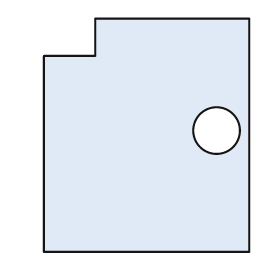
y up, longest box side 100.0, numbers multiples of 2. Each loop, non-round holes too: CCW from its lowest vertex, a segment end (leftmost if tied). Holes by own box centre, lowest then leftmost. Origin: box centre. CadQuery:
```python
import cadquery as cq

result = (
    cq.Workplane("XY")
    .moveTo(-44.0, -50.0)
    .lineTo(44.0, -50.0)
    .lineTo(44.0, 50.0)
    .lineTo(-22.0, 50.0)
    .lineTo(-22.0, 34.0)
    .lineTo(-44.0, 34.0)
    .close()
    .moveTo(30.0, 2.0)
    .circle(10.0)
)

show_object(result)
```